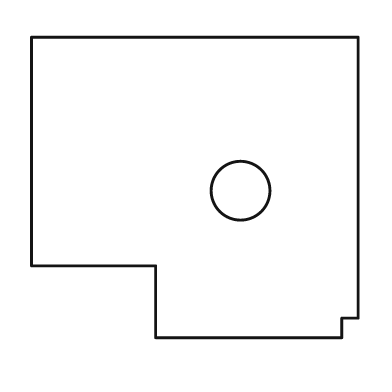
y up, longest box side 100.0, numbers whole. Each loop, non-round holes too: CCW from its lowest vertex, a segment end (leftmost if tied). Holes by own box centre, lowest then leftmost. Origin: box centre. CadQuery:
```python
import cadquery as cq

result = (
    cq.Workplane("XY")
    .moveTo(-12.0, -46.0)
    .lineTo(45.0, -46.0)
    .lineTo(45.0, -40.0)
    .lineTo(50.0, -40.0)
    .lineTo(50.0, 46.0)
    .lineTo(-50.0, 46.0)
    .lineTo(-50.0, -24.0)
    .lineTo(-12.0, -24.0)
    .close()
    .moveTo(14.0, -1.0)
    .circle(9.0)
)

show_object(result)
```